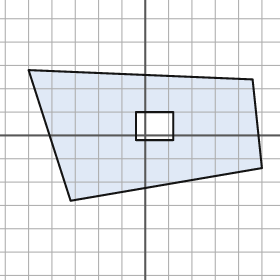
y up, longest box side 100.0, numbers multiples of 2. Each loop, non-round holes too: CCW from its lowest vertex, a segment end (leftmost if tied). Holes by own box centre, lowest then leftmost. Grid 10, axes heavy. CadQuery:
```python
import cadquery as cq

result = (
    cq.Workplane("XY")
    .moveTo(-32.0, -28.0)
    .lineTo(50.0, -14.0)
    .lineTo(46.0, 24.0)
    .lineTo(-50.0, 28.0)
    .close()
    .moveTo(-4.0, -2.0)
    .lineTo(12.0, -2.0)
    .lineTo(12.0, 10.0)
    .lineTo(-4.0, 10.0)
    .close()
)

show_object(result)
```